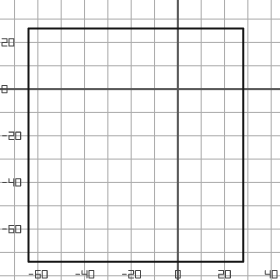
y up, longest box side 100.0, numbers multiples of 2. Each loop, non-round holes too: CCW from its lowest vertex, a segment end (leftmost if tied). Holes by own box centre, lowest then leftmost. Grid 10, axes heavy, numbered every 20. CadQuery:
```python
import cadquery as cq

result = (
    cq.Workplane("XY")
    .moveTo(-64.0, -74.0)
    .lineTo(28.0, -74.0)
    .lineTo(28.0, 26.0)
    .lineTo(-64.0, 26.0)
    .close()
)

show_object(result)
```